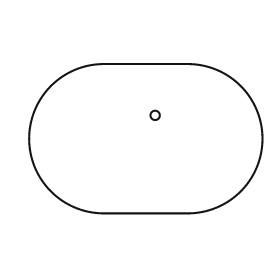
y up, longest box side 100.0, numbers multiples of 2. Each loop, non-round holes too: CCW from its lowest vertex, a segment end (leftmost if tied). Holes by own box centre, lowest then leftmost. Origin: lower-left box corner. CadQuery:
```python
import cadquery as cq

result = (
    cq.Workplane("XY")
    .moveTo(32.0, 0.0)
    .lineTo(68.0, 0.0)
    .threePointArc((100.0, 32.0), (68.0, 64.0))
    .lineTo(32.0, 64.0)
    .threePointArc((0.0, 32.0), (32.0, 0.0))
    .close()
    .moveTo(54.0, 42.0)
    .circle(2.0)
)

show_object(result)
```